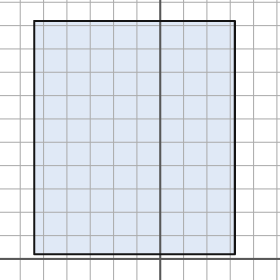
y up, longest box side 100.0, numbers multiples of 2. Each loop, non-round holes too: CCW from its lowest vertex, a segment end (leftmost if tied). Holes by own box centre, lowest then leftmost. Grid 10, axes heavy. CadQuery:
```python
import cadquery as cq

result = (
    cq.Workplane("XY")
    .moveTo(-54.0, 2.0)
    .lineTo(32.0, 2.0)
    .lineTo(32.0, 102.0)
    .lineTo(-54.0, 102.0)
    .close()
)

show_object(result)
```